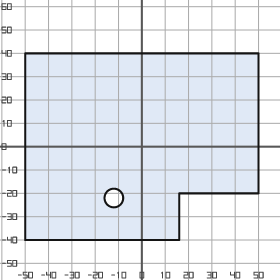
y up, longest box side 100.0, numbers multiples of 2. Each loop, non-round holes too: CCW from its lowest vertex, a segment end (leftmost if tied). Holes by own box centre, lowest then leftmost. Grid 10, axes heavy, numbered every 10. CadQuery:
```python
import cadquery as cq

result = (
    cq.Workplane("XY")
    .moveTo(-50.0, -40.0)
    .lineTo(16.0, -40.0)
    .lineTo(16.0, -20.0)
    .lineTo(50.0, -20.0)
    .lineTo(50.0, 40.0)
    .lineTo(-50.0, 40.0)
    .close()
    .moveTo(-12.0, -22.0)
    .circle(4.0)
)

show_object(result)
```